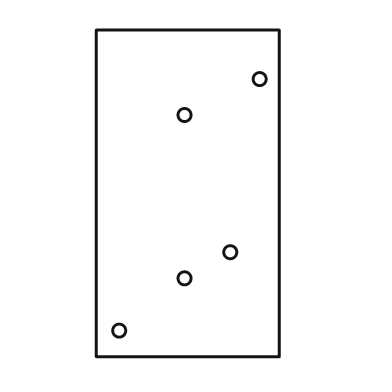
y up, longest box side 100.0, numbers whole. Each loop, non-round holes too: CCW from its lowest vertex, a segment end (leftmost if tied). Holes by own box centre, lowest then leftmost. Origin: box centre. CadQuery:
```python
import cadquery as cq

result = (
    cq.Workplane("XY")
    .moveTo(-28.0, -50.0)
    .lineTo(28.0, -50.0)
    .lineTo(28.0, 50.0)
    .lineTo(-28.0, 50.0)
    .close()
    .moveTo(-21.0, -42.0)
    .circle(2.0)
    .moveTo(-1.0, -26.0)
    .circle(2.0)
    .moveTo(13.0, -18.0)
    .circle(2.0)
    .moveTo(-1.0, 24.0)
    .circle(2.0)
    .moveTo(22.0, 35.0)
    .circle(2.0)
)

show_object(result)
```